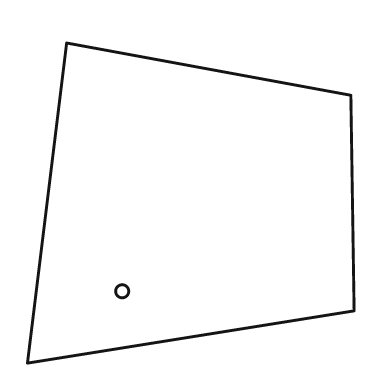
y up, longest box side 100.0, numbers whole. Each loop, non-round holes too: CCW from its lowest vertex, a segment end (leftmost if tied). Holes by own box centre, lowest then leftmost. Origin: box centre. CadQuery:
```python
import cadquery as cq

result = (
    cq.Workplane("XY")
    .moveTo(-50.0, -49.0)
    .lineTo(50.0, -33.0)
    .lineTo(49.0, 33.0)
    .lineTo(-38.0, 49.0)
    .close()
    .moveTo(-21.0, -27.0)
    .circle(2.0)
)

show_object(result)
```